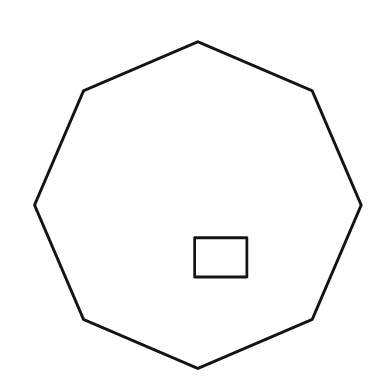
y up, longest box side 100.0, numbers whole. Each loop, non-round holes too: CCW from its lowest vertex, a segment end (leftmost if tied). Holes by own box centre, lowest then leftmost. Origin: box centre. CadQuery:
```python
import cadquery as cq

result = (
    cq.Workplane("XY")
    .moveTo(0.0, -50.0)
    .lineTo(35.0, -35.0)
    .lineTo(50.0, 0.0)
    .lineTo(35.0, 35.0)
    .lineTo(0.0, 50.0)
    .lineTo(-35.0, 35.0)
    .lineTo(-50.0, 0.0)
    .lineTo(-35.0, -35.0)
    .close()
    .moveTo(-1.0, -22.0)
    .lineTo(15.0, -22.0)
    .lineTo(15.0, -10.0)
    .lineTo(-1.0, -10.0)
    .close()
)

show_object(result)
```